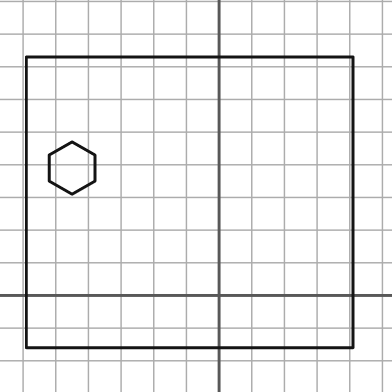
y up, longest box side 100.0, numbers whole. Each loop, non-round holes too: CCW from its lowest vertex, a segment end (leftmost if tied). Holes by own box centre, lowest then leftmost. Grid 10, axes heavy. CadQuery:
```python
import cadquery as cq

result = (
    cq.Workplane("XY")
    .moveTo(-59.0, -16.0)
    .lineTo(41.0, -16.0)
    .lineTo(41.0, 73.0)
    .lineTo(-59.0, 73.0)
    .close()
    .moveTo(-45.0, 31.0)
    .lineTo(-38.0, 35.0)
    .lineTo(-38.0, 43.0)
    .lineTo(-45.0, 47.0)
    .lineTo(-52.0, 43.0)
    .lineTo(-52.0, 35.0)
    .close()
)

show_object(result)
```